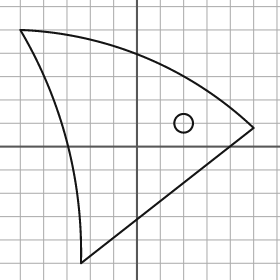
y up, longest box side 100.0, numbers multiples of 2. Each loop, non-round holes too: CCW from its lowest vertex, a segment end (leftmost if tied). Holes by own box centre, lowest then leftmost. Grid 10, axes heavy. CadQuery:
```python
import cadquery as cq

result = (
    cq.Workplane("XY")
    .moveTo(-24.0, -50.0)
    .lineTo(50.0, 8.0)
    .threePointArc((4.0, 38.0), (-50.0, 50.0))
    .threePointArc((-30.0, 2.0), (-24.0, -50.0))
    .close()
    .moveTo(20.0, 10.0)
    .circle(4.0)
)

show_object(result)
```